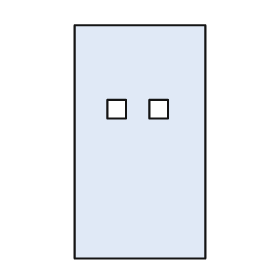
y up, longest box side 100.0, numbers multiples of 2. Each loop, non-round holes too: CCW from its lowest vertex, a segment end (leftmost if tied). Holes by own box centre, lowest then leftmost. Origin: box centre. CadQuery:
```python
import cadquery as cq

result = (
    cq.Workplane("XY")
    .moveTo(-28.0, -50.0)
    .lineTo(28.0, -50.0)
    .lineTo(28.0, 50.0)
    .lineTo(-28.0, 50.0)
    .close()
    .moveTo(-14.0, 10.0)
    .lineTo(-6.0, 10.0)
    .lineTo(-6.0, 18.0)
    .lineTo(-14.0, 18.0)
    .close()
    .moveTo(4.0, 10.0)
    .lineTo(12.0, 10.0)
    .lineTo(12.0, 18.0)
    .lineTo(4.0, 18.0)
    .close()
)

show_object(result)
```